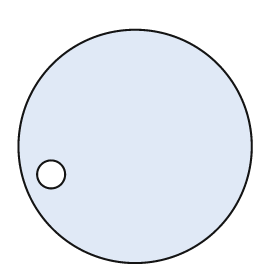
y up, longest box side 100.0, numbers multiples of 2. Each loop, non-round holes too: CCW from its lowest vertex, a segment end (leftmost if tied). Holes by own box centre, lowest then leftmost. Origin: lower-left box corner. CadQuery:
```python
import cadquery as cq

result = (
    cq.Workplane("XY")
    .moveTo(50.0, 50.0)
    .circle(50.0)
    .moveTo(14.0, 38.0)
    .circle(6.0)
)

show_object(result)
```